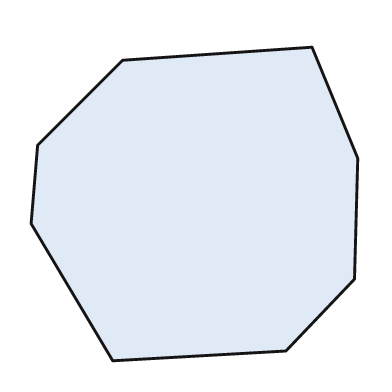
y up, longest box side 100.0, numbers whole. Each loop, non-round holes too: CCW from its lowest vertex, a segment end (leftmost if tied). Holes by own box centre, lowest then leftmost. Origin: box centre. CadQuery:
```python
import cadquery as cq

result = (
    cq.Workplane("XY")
    .moveTo(-25.0, -48.0)
    .lineTo(28.0, -45.0)
    .lineTo(49.0, -23.0)
    .lineTo(50.0, 14.0)
    .lineTo(36.0, 48.0)
    .lineTo(-22.0, 44.0)
    .lineTo(-48.0, 18.0)
    .lineTo(-50.0, -6.0)
    .close()
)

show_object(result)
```